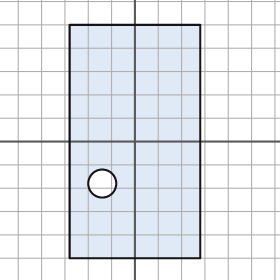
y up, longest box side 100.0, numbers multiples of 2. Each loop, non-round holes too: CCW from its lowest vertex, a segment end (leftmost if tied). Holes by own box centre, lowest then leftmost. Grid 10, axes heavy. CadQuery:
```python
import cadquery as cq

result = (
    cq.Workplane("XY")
    .moveTo(-28.0, -50.0)
    .lineTo(28.0, -50.0)
    .lineTo(28.0, 50.0)
    .lineTo(-28.0, 50.0)
    .close()
    .moveTo(-14.0, -18.0)
    .circle(6.0)
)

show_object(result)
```